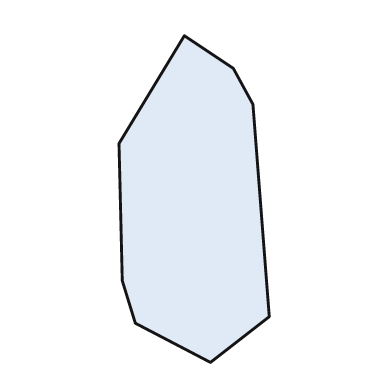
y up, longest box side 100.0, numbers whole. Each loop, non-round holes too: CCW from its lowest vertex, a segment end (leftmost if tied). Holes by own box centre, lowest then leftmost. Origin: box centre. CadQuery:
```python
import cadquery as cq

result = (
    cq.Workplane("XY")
    .moveTo(5.0, -50.0)
    .lineTo(23.0, -36.0)
    .lineTo(18.0, 29.0)
    .lineTo(12.0, 40.0)
    .lineTo(-3.0, 50.0)
    .lineTo(-23.0, 17.0)
    .lineTo(-22.0, -25.0)
    .lineTo(-18.0, -38.0)
    .close()
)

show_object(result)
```